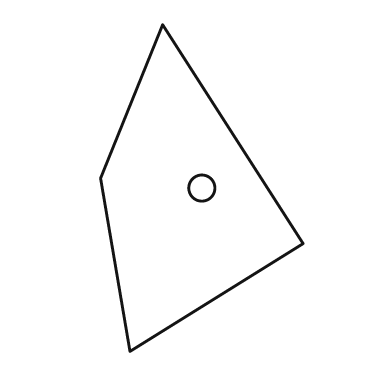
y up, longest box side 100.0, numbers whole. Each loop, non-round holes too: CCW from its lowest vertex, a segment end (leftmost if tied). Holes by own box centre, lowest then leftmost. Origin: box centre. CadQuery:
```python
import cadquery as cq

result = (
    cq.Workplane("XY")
    .moveTo(-22.0, -50.0)
    .lineTo(31.0, -17.0)
    .lineTo(-12.0, 50.0)
    .lineTo(-31.0, 3.0)
    .close()
    .moveTo(0.0, 0.0)
    .circle(4.0)
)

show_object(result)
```